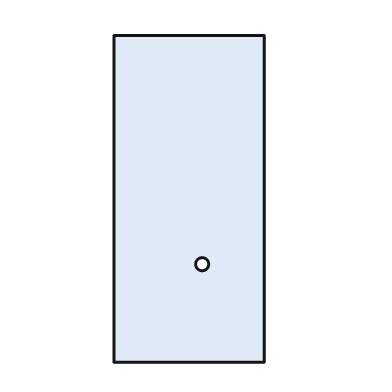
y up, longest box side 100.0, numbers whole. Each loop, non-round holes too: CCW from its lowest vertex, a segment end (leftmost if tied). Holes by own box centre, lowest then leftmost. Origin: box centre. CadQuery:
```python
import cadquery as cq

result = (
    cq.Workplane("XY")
    .moveTo(-23.0, -50.0)
    .lineTo(23.0, -50.0)
    .lineTo(23.0, 50.0)
    .lineTo(-23.0, 50.0)
    .close()
    .moveTo(4.0, -20.0)
    .circle(2.0)
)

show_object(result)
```